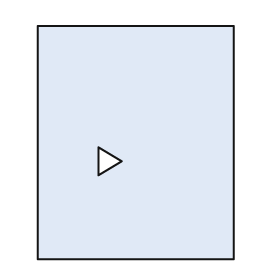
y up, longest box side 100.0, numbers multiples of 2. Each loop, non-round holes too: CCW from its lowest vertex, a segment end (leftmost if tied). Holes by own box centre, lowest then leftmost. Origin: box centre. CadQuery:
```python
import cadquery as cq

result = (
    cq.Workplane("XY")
    .moveTo(-42.0, -50.0)
    .lineTo(42.0, -50.0)
    .lineTo(42.0, 50.0)
    .lineTo(-42.0, 50.0)
    .close()
    .moveTo(-16.0, -14.0)
    .lineTo(-6.0, -8.0)
    .lineTo(-16.0, -2.0)
    .close()
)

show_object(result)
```